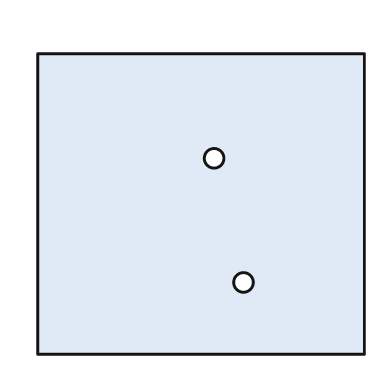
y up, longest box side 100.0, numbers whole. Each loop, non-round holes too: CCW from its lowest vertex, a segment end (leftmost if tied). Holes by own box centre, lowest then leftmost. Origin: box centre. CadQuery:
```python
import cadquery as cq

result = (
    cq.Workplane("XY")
    .moveTo(-50.0, -46.0)
    .lineTo(50.0, -46.0)
    .lineTo(50.0, 46.0)
    .lineTo(-50.0, 46.0)
    .close()
    .moveTo(13.0, -24.0)
    .circle(3.0)
    .moveTo(4.0, 14.0)
    .circle(3.0)
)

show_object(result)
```